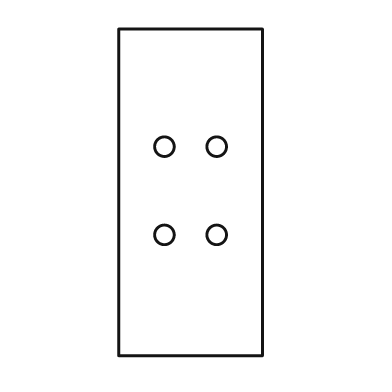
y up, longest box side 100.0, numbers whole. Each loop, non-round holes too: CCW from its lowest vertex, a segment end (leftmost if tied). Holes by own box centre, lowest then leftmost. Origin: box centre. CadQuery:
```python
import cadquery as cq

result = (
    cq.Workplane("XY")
    .moveTo(-22.0, -50.0)
    .lineTo(22.0, -50.0)
    .lineTo(22.0, 50.0)
    .lineTo(-22.0, 50.0)
    .close()
    .moveTo(-8.0, -13.0)
    .circle(3.0)
    .moveTo(8.0, -13.0)
    .circle(3.0)
    .moveTo(-8.0, 14.0)
    .circle(3.0)
    .moveTo(8.0, 14.0)
    .circle(3.0)
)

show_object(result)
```